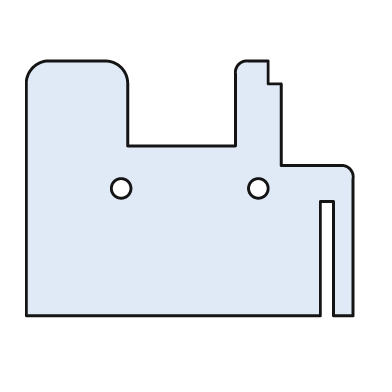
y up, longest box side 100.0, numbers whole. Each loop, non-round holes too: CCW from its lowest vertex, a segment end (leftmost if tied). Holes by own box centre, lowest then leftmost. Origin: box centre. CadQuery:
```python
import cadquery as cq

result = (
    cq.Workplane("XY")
    .moveTo(-50.0, -39.0)
    .lineTo(40.0, -39.0)
    .lineTo(40.0, -4.0)
    .lineTo(44.0, -4.0)
    .lineTo(44.0, -39.0)
    .lineTo(50.0, -39.0)
    .lineTo(50.0, 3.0)
    .threePointArc((49.0, 6.0), (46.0, 7.0))
    .lineTo(28.0, 7.0)
    .lineTo(28.0, 32.0)
    .lineTo(24.0, 32.0)
    .lineTo(24.0, 39.0)
    .lineTo(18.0, 39.0)
    .threePointArc((15.0, 38.0), (14.0, 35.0))
    .lineTo(14.0, 13.0)
    .lineTo(-19.0, 13.0)
    .lineTo(-19.0, 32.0)
    .threePointArc((-21.0, 37.0), (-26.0, 39.0))
    .lineTo(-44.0, 39.0)
    .threePointArc((-48.0, 37.0), (-50.0, 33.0))
    .close()
    .moveTo(-21.0, 0.0)
    .circle(3.0)
    .moveTo(21.0, 0.0)
    .circle(3.0)
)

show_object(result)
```